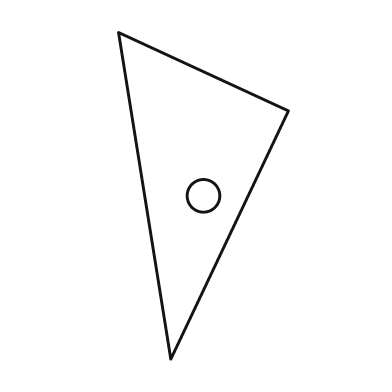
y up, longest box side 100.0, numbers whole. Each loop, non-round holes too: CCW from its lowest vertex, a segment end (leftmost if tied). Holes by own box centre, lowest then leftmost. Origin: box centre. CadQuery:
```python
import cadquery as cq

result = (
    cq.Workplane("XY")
    .moveTo(-10.0, -50.0)
    .lineTo(26.0, 26.0)
    .lineTo(-26.0, 50.0)
    .close()
    .moveTo(0.0, 0.0)
    .circle(5.0)
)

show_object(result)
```